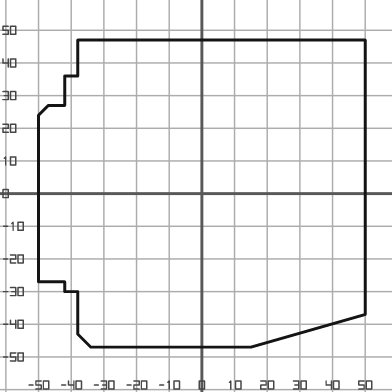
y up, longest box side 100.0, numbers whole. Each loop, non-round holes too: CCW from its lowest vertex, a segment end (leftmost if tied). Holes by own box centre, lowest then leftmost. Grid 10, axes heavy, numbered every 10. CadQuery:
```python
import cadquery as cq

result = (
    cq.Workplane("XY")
    .moveTo(-34.0, -47.0)
    .lineTo(15.0, -47.0)
    .lineTo(50.0, -37.0)
    .lineTo(50.0, 47.0)
    .lineTo(-38.0, 47.0)
    .lineTo(-38.0, 36.0)
    .lineTo(-42.0, 36.0)
    .lineTo(-42.0, 27.0)
    .lineTo(-47.0, 27.0)
    .lineTo(-50.0, 24.0)
    .lineTo(-50.0, -27.0)
    .lineTo(-42.0, -27.0)
    .lineTo(-42.0, -30.0)
    .lineTo(-38.0, -30.0)
    .lineTo(-38.0, -43.0)
    .close()
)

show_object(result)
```